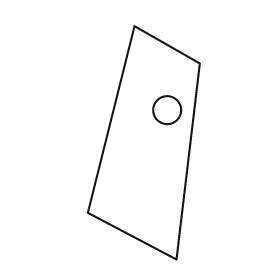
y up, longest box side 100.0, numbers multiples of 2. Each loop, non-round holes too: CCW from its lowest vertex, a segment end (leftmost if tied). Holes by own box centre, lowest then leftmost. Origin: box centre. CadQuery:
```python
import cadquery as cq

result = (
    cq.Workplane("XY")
    .moveTo(14.0, -50.0)
    .lineTo(24.0, 34.0)
    .lineTo(-4.0, 50.0)
    .lineTo(-24.0, -30.0)
    .close()
    .moveTo(10.0, 14.0)
    .circle(6.0)
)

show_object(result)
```